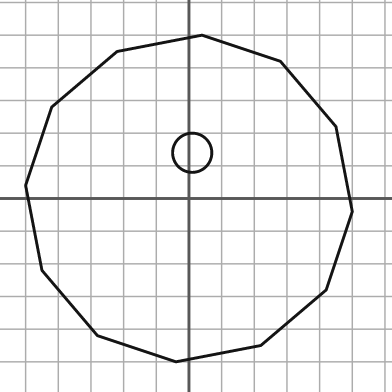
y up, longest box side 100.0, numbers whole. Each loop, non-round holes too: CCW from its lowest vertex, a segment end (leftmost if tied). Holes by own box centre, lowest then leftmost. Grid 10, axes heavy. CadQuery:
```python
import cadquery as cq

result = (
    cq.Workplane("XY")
    .moveTo(-4.0, -50.0)
    .lineTo(22.0, -45.0)
    .lineTo(42.0, -28.0)
    .lineTo(50.0, -4.0)
    .lineTo(45.0, 22.0)
    .lineTo(28.0, 42.0)
    .lineTo(4.0, 50.0)
    .lineTo(-22.0, 45.0)
    .lineTo(-42.0, 28.0)
    .lineTo(-50.0, 4.0)
    .lineTo(-45.0, -22.0)
    .lineTo(-28.0, -42.0)
    .close()
    .moveTo(1.0, 14.0)
    .circle(6.0)
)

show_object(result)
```